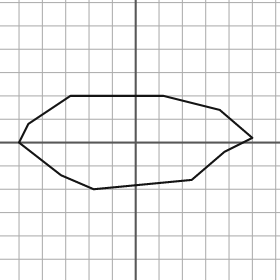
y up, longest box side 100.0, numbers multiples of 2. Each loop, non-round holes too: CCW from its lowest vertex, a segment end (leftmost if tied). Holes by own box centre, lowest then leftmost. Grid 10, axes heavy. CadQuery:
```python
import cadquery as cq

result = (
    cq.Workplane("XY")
    .moveTo(-18.0, -20.0)
    .lineTo(24.0, -16.0)
    .lineTo(38.0, -4.0)
    .lineTo(50.0, 2.0)
    .lineTo(36.0, 14.0)
    .lineTo(12.0, 20.0)
    .lineTo(-28.0, 20.0)
    .lineTo(-46.0, 8.0)
    .lineTo(-50.0, 0.0)
    .lineTo(-32.0, -14.0)
    .close()
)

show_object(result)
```